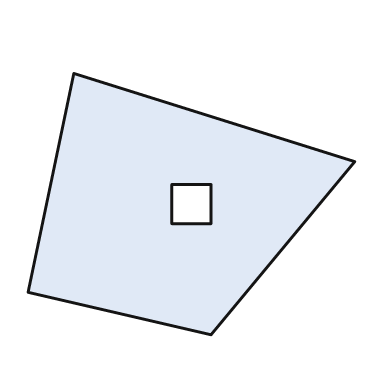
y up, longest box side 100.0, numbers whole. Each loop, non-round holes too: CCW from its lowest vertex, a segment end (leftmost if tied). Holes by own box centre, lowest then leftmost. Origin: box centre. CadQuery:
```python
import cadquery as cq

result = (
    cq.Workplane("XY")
    .moveTo(6.0, -40.0)
    .lineTo(50.0, 13.0)
    .lineTo(-36.0, 40.0)
    .lineTo(-50.0, -27.0)
    .close()
    .moveTo(-6.0, -6.0)
    .lineTo(6.0, -6.0)
    .lineTo(6.0, 6.0)
    .lineTo(-6.0, 6.0)
    .close()
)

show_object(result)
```